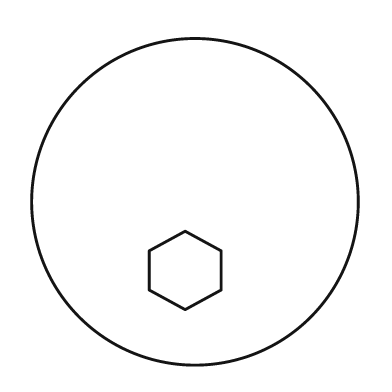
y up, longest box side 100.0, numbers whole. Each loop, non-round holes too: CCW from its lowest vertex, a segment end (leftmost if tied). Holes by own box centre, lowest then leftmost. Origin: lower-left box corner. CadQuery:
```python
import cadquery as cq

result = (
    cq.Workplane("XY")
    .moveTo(50.0, 50.0)
    .circle(50.0)
    .moveTo(47.0, 17.0)
    .lineTo(58.0, 23.0)
    .lineTo(58.0, 35.0)
    .lineTo(47.0, 41.0)
    .lineTo(36.0, 35.0)
    .lineTo(36.0, 23.0)
    .close()
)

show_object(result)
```